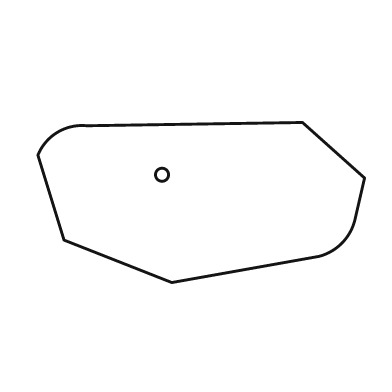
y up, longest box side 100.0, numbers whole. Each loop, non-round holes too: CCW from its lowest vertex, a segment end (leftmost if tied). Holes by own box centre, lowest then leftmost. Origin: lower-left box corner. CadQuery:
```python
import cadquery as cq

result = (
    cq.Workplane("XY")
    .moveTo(41.0, 0.0)
    .lineTo(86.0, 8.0)
    .threePointArc((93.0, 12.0), (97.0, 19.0))
    .lineTo(100.0, 32.0)
    .lineTo(81.0, 49.0)
    .lineTo(15.0, 48.0)
    .threePointArc((6.0, 46.0), (0.0, 39.0))
    .lineTo(8.0, 13.0)
    .close()
    .moveTo(38.0, 33.0)
    .circle(2.0)
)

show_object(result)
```